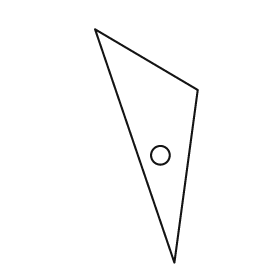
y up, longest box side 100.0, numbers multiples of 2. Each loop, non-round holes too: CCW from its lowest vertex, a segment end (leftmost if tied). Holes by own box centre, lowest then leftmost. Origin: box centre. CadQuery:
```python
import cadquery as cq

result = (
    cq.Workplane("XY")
    .moveTo(12.0, -50.0)
    .lineTo(22.0, 24.0)
    .lineTo(-22.0, 50.0)
    .close()
    .moveTo(6.0, -4.0)
    .circle(4.0)
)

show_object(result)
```